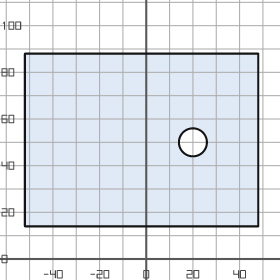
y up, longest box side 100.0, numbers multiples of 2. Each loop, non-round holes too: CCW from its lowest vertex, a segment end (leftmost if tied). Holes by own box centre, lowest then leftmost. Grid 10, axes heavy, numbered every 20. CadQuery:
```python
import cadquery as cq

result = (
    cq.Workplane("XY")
    .moveTo(-52.0, 14.0)
    .lineTo(48.0, 14.0)
    .lineTo(48.0, 88.0)
    .lineTo(-52.0, 88.0)
    .close()
    .moveTo(20.0, 50.0)
    .circle(6.0)
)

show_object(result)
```